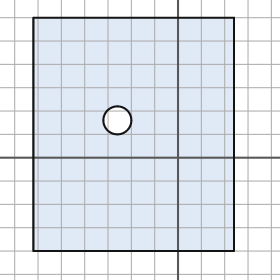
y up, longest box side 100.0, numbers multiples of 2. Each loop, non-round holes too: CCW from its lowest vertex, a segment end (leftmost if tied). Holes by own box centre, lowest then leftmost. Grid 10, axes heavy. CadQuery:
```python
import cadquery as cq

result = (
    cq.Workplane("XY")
    .moveTo(-62.0, -40.0)
    .lineTo(24.0, -40.0)
    .lineTo(24.0, 60.0)
    .lineTo(-62.0, 60.0)
    .close()
    .moveTo(-26.0, 16.0)
    .circle(6.0)
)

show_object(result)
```